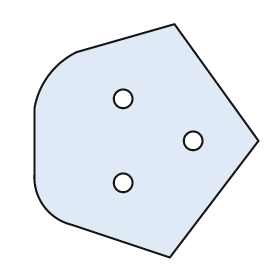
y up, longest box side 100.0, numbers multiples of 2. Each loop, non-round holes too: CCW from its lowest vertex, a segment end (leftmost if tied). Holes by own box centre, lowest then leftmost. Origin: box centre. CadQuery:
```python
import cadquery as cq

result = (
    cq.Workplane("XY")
    .moveTo(10.0, -50.0)
    .lineTo(48.0, 0.0)
    .lineTo(12.0, 50.0)
    .lineTo(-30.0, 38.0)
    .threePointArc((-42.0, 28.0), (-48.0, 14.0))
    .lineTo(-48.0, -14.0)
    .threePointArc((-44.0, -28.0), (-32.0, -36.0))
    .close()
    .moveTo(-10.0, -18.0)
    .circle(4.0)
    .moveTo(20.0, 0.0)
    .circle(4.0)
    .moveTo(-10.0, 18.0)
    .circle(4.0)
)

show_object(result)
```